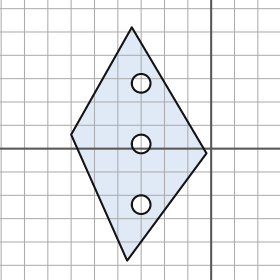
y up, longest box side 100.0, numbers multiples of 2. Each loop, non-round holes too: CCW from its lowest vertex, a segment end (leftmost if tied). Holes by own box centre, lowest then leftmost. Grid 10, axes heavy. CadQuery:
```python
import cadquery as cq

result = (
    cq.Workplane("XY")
    .moveTo(-36.0, -48.0)
    .lineTo(-2.0, -2.0)
    .lineTo(-34.0, 52.0)
    .lineTo(-60.0, 6.0)
    .close()
    .moveTo(-30.0, -24.0)
    .circle(4.0)
    .moveTo(-30.0, 2.0)
    .circle(4.0)
    .moveTo(-30.0, 28.0)
    .circle(4.0)
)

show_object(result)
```